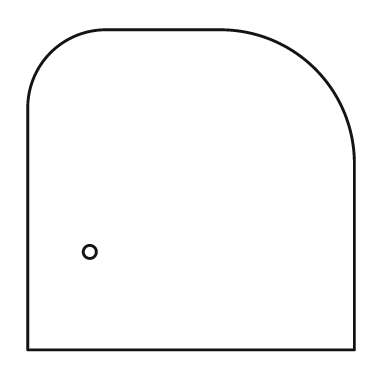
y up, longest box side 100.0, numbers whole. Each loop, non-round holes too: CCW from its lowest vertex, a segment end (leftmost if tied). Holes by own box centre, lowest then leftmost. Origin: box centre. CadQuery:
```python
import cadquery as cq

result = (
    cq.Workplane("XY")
    .moveTo(-50.0, -49.0)
    .lineTo(50.0, -49.0)
    .lineTo(50.0, 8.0)
    .threePointArc((38.0, 37.0), (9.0, 49.0))
    .lineTo(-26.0, 49.0)
    .threePointArc((-43.0, 42.0), (-50.0, 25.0))
    .close()
    .moveTo(-31.0, -19.0)
    .circle(2.0)
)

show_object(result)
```